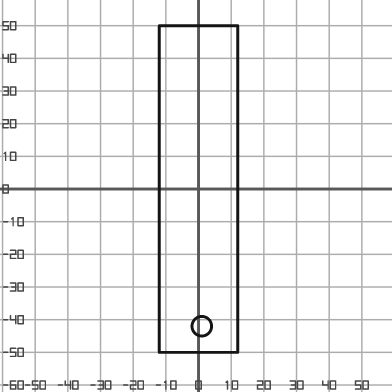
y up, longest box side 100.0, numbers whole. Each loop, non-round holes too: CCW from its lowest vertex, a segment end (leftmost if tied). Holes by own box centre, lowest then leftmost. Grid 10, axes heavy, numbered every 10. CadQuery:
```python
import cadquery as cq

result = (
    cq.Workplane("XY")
    .moveTo(-12.0, -50.0)
    .lineTo(12.0, -50.0)
    .lineTo(12.0, 50.0)
    .lineTo(-12.0, 50.0)
    .close()
    .moveTo(1.0, -42.0)
    .circle(3.0)
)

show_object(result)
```